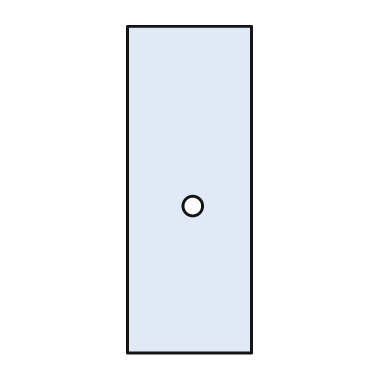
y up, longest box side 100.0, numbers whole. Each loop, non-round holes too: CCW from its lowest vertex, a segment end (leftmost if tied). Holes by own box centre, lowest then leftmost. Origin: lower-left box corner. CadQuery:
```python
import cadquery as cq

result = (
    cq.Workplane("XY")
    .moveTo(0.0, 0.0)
    .lineTo(38.0, 0.0)
    .lineTo(38.0, 100.0)
    .lineTo(0.0, 100.0)
    .close()
    .moveTo(20.0, 45.0)
    .circle(3.0)
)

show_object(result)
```